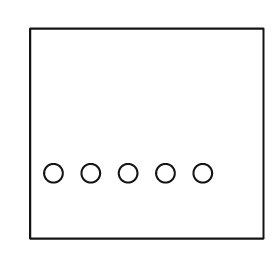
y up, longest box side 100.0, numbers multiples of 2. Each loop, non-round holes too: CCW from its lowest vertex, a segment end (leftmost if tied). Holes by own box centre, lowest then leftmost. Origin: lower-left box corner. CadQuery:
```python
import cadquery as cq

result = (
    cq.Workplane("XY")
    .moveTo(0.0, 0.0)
    .lineTo(100.0, 0.0)
    .lineTo(100.0, 90.0)
    .lineTo(0.0, 90.0)
    .close()
    .moveTo(10.0, 28.0)
    .circle(4.0)
    .moveTo(26.0, 28.0)
    .circle(4.0)
    .moveTo(42.0, 28.0)
    .circle(4.0)
    .moveTo(58.0, 28.0)
    .circle(4.0)
    .moveTo(74.0, 28.0)
    .circle(4.0)
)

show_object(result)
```